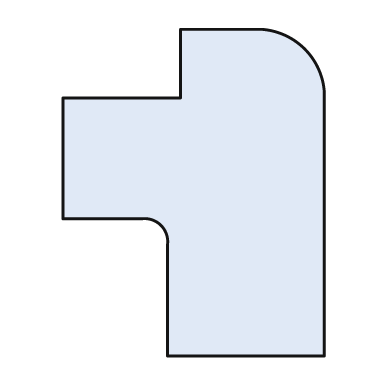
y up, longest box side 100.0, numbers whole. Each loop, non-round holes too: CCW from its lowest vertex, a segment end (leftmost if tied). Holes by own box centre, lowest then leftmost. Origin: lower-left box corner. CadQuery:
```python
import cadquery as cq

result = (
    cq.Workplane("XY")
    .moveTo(32.0, 0.0)
    .lineTo(80.0, 0.0)
    .lineTo(80.0, 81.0)
    .threePointArc((74.0, 94.0), (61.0, 100.0))
    .lineTo(36.0, 100.0)
    .lineTo(36.0, 79.0)
    .lineTo(0.0, 79.0)
    .lineTo(0.0, 42.0)
    .lineTo(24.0, 42.0)
    .threePointArc((30.0, 40.0), (32.0, 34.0))
    .close()
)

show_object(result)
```